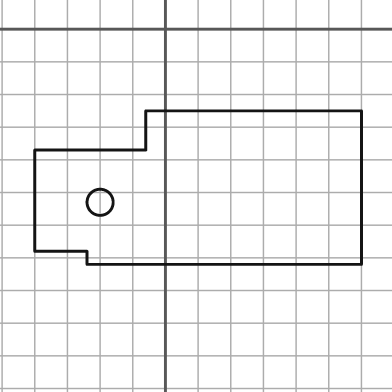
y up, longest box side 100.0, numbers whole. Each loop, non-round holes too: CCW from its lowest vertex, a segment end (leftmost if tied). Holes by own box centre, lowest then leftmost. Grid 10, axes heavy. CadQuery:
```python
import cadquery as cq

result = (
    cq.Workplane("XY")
    .moveTo(-24.0, -72.0)
    .lineTo(60.0, -72.0)
    .lineTo(60.0, -25.0)
    .lineTo(-6.0, -25.0)
    .lineTo(-6.0, -37.0)
    .lineTo(-40.0, -37.0)
    .lineTo(-40.0, -68.0)
    .lineTo(-24.0, -68.0)
    .close()
    .moveTo(-20.0, -53.0)
    .circle(4.0)
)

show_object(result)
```